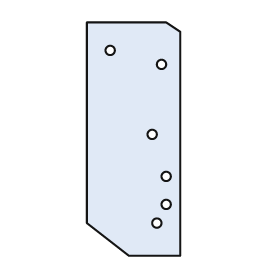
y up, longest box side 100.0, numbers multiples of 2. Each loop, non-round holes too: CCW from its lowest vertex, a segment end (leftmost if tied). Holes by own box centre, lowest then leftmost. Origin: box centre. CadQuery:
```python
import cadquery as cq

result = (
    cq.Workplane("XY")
    .moveTo(-2.0, -50.0)
    .lineTo(20.0, -50.0)
    .lineTo(20.0, 46.0)
    .lineTo(14.0, 50.0)
    .lineTo(-20.0, 50.0)
    .lineTo(-20.0, -36.0)
    .close()
    .moveTo(10.0, -36.0)
    .circle(2.0)
    .moveTo(14.0, -28.0)
    .circle(2.0)
    .moveTo(14.0, -16.0)
    .circle(2.0)
    .moveTo(8.0, 2.0)
    .circle(2.0)
    .moveTo(12.0, 32.0)
    .circle(2.0)
    .moveTo(-10.0, 38.0)
    .circle(2.0)
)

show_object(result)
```